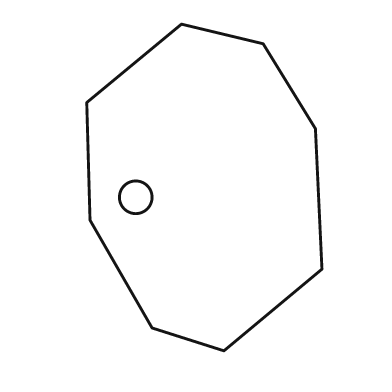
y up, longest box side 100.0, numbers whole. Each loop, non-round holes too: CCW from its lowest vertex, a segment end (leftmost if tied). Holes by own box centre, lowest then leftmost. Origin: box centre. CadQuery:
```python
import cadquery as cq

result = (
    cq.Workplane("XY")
    .moveTo(6.0, -50.0)
    .lineTo(36.0, -25.0)
    .lineTo(34.0, 18.0)
    .lineTo(18.0, 44.0)
    .lineTo(-7.0, 50.0)
    .lineTo(-36.0, 26.0)
    .lineTo(-35.0, -10.0)
    .lineTo(-16.0, -43.0)
    .close()
    .moveTo(-21.0, -3.0)
    .circle(5.0)
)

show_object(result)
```